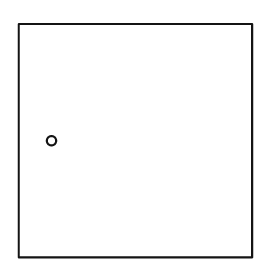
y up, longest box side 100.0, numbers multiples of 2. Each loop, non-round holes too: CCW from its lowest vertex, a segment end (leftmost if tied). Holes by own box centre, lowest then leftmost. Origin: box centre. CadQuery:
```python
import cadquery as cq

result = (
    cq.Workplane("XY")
    .moveTo(-50.0, -50.0)
    .lineTo(50.0, -50.0)
    .lineTo(50.0, 50.0)
    .lineTo(-50.0, 50.0)
    .close()
    .moveTo(-36.0, 0.0)
    .circle(2.0)
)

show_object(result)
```